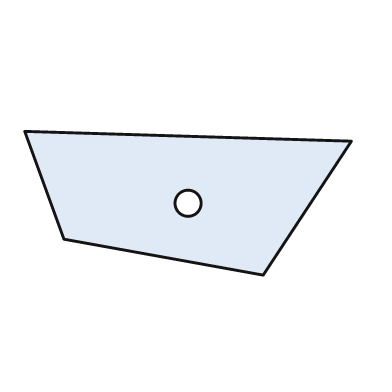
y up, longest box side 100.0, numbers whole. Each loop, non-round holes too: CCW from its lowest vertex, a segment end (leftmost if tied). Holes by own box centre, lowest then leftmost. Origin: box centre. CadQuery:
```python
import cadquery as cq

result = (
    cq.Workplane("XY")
    .moveTo(23.0, -22.0)
    .lineTo(50.0, 19.0)
    .lineTo(-50.0, 22.0)
    .lineTo(-38.0, -11.0)
    .close()
    .moveTo(0.0, 0.0)
    .circle(4.0)
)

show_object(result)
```